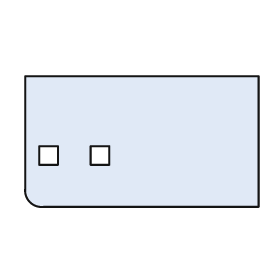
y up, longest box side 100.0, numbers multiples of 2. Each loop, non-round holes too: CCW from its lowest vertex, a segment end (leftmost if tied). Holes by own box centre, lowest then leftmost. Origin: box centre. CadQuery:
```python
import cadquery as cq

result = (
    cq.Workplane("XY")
    .moveTo(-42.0, -28.0)
    .lineTo(50.0, -28.0)
    .lineTo(50.0, 28.0)
    .lineTo(-50.0, 28.0)
    .lineTo(-50.0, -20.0)
    .threePointArc((-48.0, -26.0), (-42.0, -28.0))
    .close()
    .moveTo(-44.0, -10.0)
    .lineTo(-36.0, -10.0)
    .lineTo(-36.0, -2.0)
    .lineTo(-44.0, -2.0)
    .close()
    .moveTo(-22.0, -10.0)
    .lineTo(-14.0, -10.0)
    .lineTo(-14.0, -2.0)
    .lineTo(-22.0, -2.0)
    .close()
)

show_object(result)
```